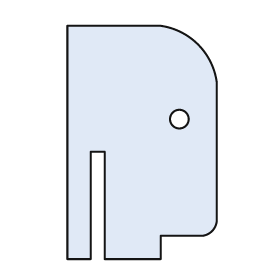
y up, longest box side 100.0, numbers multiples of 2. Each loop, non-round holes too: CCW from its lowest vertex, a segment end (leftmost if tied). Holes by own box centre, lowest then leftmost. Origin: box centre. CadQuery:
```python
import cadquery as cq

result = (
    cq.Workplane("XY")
    .moveTo(-32.0, -50.0)
    .lineTo(-22.0, -50.0)
    .lineTo(-22.0, -4.0)
    .lineTo(-16.0, -4.0)
    .lineTo(-16.0, -50.0)
    .lineTo(8.0, -50.0)
    .lineTo(8.0, -40.0)
    .lineTo(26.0, -40.0)
    .threePointArc((30.0, -38.0), (32.0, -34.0))
    .lineTo(32.0, 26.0)
    .threePointArc((24.0, 42.0), (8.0, 50.0))
    .lineTo(-32.0, 50.0)
    .close()
    .moveTo(16.0, 10.0)
    .circle(4.0)
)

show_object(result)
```